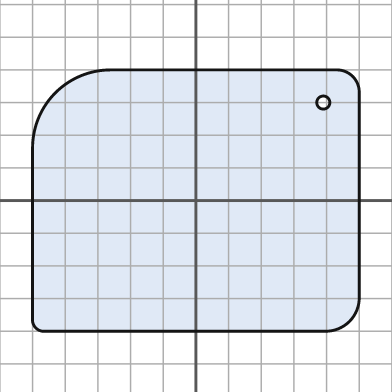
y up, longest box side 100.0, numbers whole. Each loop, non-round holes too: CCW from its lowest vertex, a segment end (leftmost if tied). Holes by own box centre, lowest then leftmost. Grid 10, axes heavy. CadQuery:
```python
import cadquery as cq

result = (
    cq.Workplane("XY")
    .moveTo(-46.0, -40.0)
    .lineTo(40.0, -40.0)
    .threePointArc((47.0, -37.0), (50.0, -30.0))
    .lineTo(50.0, 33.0)
    .threePointArc((48.0, 38.0), (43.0, 40.0))
    .lineTo(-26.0, 40.0)
    .threePointArc((-43.0, 33.0), (-50.0, 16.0))
    .lineTo(-50.0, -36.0)
    .threePointArc((-49.0, -39.0), (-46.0, -40.0))
    .close()
    .moveTo(39.0, 30.0)
    .circle(2.0)
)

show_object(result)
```